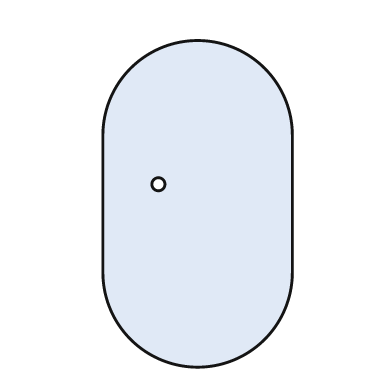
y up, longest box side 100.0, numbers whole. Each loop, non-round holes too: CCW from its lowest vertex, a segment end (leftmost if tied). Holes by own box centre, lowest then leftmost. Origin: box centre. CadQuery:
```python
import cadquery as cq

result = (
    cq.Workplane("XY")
    .moveTo(-29.0, -21.0)
    .threePointArc((0.0, -50.0), (29.0, -21.0))
    .lineTo(29.0, 21.0)
    .threePointArc((0.0, 50.0), (-29.0, 21.0))
    .close()
    .moveTo(-12.0, 6.0)
    .circle(2.0)
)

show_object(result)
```